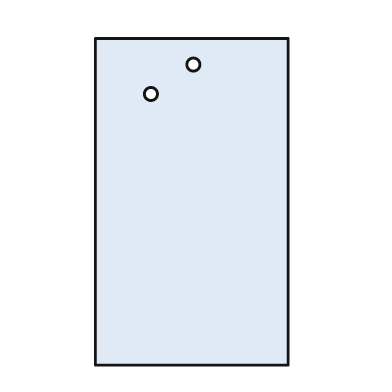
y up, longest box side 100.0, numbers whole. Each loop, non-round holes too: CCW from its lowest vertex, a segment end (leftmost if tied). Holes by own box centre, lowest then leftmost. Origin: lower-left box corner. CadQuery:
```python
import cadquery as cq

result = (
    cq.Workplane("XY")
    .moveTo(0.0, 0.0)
    .lineTo(59.0, 0.0)
    .lineTo(59.0, 100.0)
    .lineTo(0.0, 100.0)
    .close()
    .moveTo(17.0, 83.0)
    .circle(2.0)
    .moveTo(30.0, 92.0)
    .circle(2.0)
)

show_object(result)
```